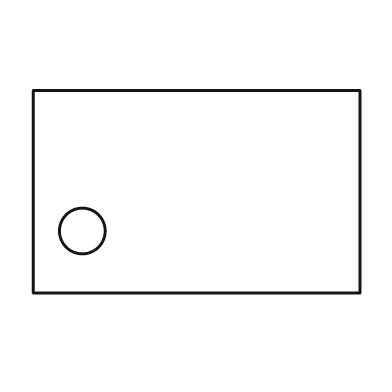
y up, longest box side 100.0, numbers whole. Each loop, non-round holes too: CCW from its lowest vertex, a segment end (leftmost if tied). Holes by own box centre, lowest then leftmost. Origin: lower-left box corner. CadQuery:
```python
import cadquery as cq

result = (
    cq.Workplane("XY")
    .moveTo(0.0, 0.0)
    .lineTo(100.0, 0.0)
    .lineTo(100.0, 62.0)
    .lineTo(0.0, 62.0)
    .close()
    .moveTo(15.0, 19.0)
    .circle(7.0)
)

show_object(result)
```